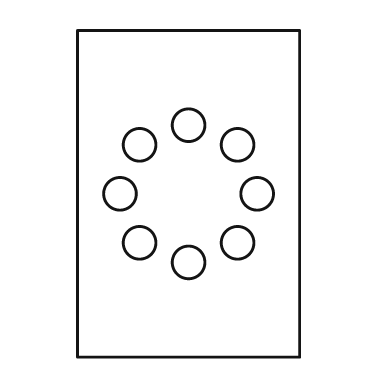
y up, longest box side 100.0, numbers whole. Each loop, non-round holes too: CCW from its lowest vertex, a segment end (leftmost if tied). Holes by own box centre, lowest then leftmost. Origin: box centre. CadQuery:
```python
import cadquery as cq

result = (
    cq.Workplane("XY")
    .moveTo(-34.0, -50.0)
    .lineTo(34.0, -50.0)
    .lineTo(34.0, 50.0)
    .lineTo(-34.0, 50.0)
    .close()
    .moveTo(0.0, -21.0)
    .circle(5.0)
    .moveTo(-15.0, -15.0)
    .circle(5.0)
    .moveTo(15.0, -15.0)
    .circle(5.0)
    .moveTo(-21.0, 0.0)
    .circle(5.0)
    .moveTo(21.0, 0.0)
    .circle(5.0)
    .moveTo(-15.0, 15.0)
    .circle(5.0)
    .moveTo(15.0, 15.0)
    .circle(5.0)
    .moveTo(0.0, 21.0)
    .circle(5.0)
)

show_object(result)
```